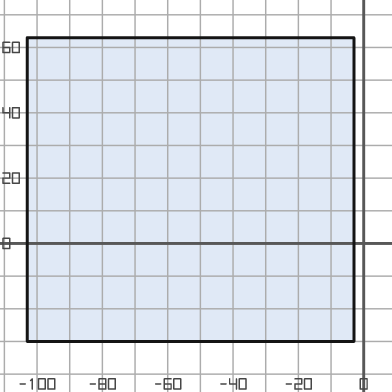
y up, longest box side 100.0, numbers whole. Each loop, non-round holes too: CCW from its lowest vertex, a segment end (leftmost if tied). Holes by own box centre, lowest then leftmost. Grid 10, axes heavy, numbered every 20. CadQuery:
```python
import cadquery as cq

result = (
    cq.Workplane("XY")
    .moveTo(-103.0, -30.0)
    .lineTo(-3.0, -30.0)
    .lineTo(-3.0, 63.0)
    .lineTo(-103.0, 63.0)
    .close()
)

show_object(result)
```